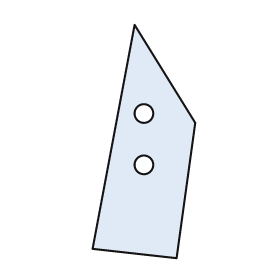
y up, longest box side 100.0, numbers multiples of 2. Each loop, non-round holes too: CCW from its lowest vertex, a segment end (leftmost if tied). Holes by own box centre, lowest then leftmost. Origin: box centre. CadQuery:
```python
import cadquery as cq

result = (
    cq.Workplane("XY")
    .moveTo(14.0, -50.0)
    .lineTo(22.0, 8.0)
    .lineTo(-4.0, 50.0)
    .lineTo(-22.0, -46.0)
    .close()
    .moveTo(0.0, -10.0)
    .circle(4.0)
    .moveTo(0.0, 12.0)
    .circle(4.0)
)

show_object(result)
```